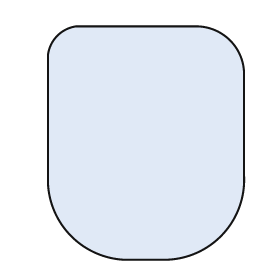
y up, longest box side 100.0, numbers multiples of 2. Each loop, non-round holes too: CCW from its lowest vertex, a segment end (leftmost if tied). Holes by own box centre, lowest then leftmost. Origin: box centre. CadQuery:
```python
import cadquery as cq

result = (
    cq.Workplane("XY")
    .moveTo(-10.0, -50.0)
    .lineTo(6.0, -50.0)
    .threePointArc((32.0, -40.0), (42.0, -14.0))
    .lineTo(42.0, 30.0)
    .threePointArc((36.0, 44.0), (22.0, 50.0))
    .lineTo(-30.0, 50.0)
    .threePointArc((-38.0, 46.0), (-42.0, 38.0))
    .lineTo(-42.0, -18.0)
    .threePointArc((-32.0, -40.0), (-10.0, -50.0))
    .close()
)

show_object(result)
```